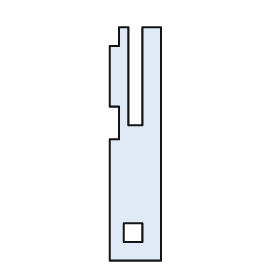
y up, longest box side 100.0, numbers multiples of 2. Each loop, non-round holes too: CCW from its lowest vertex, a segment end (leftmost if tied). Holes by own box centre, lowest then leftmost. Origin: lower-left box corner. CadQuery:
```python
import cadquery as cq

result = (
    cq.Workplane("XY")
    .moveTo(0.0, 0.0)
    .lineTo(22.0, 0.0)
    .lineTo(22.0, 100.0)
    .lineTo(14.0, 100.0)
    .lineTo(14.0, 58.0)
    .lineTo(8.0, 58.0)
    .lineTo(8.0, 100.0)
    .lineTo(4.0, 100.0)
    .lineTo(4.0, 92.0)
    .lineTo(0.0, 92.0)
    .lineTo(0.0, 66.0)
    .lineTo(4.0, 66.0)
    .lineTo(4.0, 52.0)
    .lineTo(0.0, 52.0)
    .close()
    .moveTo(6.0, 8.0)
    .lineTo(14.0, 8.0)
    .lineTo(14.0, 16.0)
    .lineTo(6.0, 16.0)
    .close()
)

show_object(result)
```